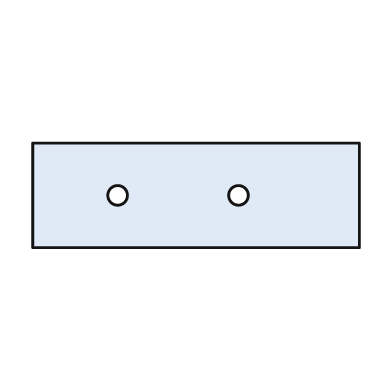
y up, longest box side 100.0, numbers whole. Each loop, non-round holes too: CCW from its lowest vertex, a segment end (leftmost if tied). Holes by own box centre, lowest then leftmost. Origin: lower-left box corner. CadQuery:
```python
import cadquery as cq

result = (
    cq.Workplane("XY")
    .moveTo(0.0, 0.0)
    .lineTo(100.0, 0.0)
    .lineTo(100.0, 32.0)
    .lineTo(0.0, 32.0)
    .close()
    .moveTo(26.0, 16.0)
    .circle(3.0)
    .moveTo(63.0, 16.0)
    .circle(3.0)
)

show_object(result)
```